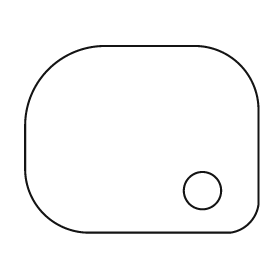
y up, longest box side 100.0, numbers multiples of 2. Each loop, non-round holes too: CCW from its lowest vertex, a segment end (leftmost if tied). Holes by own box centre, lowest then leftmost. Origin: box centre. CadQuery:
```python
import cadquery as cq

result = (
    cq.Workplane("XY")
    .moveTo(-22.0, -40.0)
    .lineTo(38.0, -40.0)
    .threePointArc((46.0, -36.0), (50.0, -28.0))
    .lineTo(50.0, 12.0)
    .threePointArc((42.0, 32.0), (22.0, 40.0))
    .lineTo(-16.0, 40.0)
    .threePointArc((-40.0, 30.0), (-50.0, 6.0))
    .lineTo(-50.0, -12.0)
    .threePointArc((-42.0, -32.0), (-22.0, -40.0))
    .close()
    .moveTo(26.0, -22.0)
    .circle(8.0)
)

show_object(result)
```